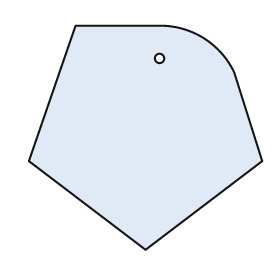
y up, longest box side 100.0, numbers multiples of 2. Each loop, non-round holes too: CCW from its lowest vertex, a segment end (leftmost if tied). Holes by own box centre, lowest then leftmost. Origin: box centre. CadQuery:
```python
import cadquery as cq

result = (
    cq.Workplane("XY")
    .moveTo(0.0, -48.0)
    .lineTo(50.0, -10.0)
    .lineTo(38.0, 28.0)
    .threePointArc((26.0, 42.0), (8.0, 48.0))
    .lineTo(-30.0, 48.0)
    .lineTo(-50.0, -10.0)
    .close()
    .moveTo(6.0, 34.0)
    .circle(2.0)
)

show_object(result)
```